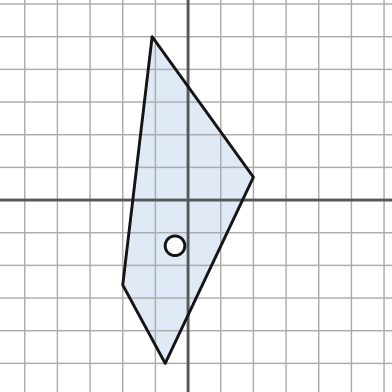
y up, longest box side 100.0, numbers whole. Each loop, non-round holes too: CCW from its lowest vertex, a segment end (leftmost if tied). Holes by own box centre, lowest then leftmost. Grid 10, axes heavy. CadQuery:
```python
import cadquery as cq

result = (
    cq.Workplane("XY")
    .moveTo(-7.0, -50.0)
    .lineTo(20.0, 7.0)
    .lineTo(-11.0, 50.0)
    .lineTo(-20.0, -26.0)
    .close()
    .moveTo(-4.0, -14.0)
    .circle(3.0)
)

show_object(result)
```